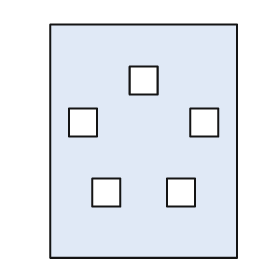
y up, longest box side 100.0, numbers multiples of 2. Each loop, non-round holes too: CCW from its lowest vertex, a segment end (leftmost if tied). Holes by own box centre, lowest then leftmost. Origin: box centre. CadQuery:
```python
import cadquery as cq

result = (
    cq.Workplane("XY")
    .moveTo(-40.0, -50.0)
    .lineTo(40.0, -50.0)
    .lineTo(40.0, 50.0)
    .lineTo(-40.0, 50.0)
    .close()
    .moveTo(-22.0, -28.0)
    .lineTo(-10.0, -28.0)
    .lineTo(-10.0, -16.0)
    .lineTo(-22.0, -16.0)
    .close()
    .moveTo(10.0, -28.0)
    .lineTo(22.0, -28.0)
    .lineTo(22.0, -16.0)
    .lineTo(10.0, -16.0)
    .close()
    .moveTo(-32.0, 2.0)
    .lineTo(-20.0, 2.0)
    .lineTo(-20.0, 14.0)
    .lineTo(-32.0, 14.0)
    .close()
    .moveTo(20.0, 2.0)
    .lineTo(32.0, 2.0)
    .lineTo(32.0, 14.0)
    .lineTo(20.0, 14.0)
    .close()
    .moveTo(-6.0, 20.0)
    .lineTo(6.0, 20.0)
    .lineTo(6.0, 32.0)
    .lineTo(-6.0, 32.0)
    .close()
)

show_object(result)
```